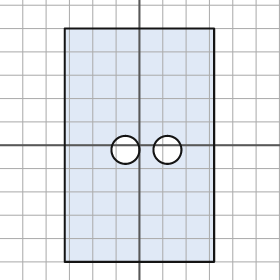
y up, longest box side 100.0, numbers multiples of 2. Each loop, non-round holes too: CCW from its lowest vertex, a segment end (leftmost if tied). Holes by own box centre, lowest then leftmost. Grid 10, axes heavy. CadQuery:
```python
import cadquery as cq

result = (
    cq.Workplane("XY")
    .moveTo(-32.0, -50.0)
    .lineTo(32.0, -50.0)
    .lineTo(32.0, 50.0)
    .lineTo(-32.0, 50.0)
    .close()
    .moveTo(-6.0, -2.0)
    .circle(6.0)
    .moveTo(12.0, -2.0)
    .circle(6.0)
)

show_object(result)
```